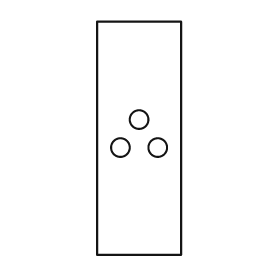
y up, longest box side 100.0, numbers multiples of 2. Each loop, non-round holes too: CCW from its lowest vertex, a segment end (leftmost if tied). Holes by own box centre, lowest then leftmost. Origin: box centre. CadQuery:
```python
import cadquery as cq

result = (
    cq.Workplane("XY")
    .moveTo(-18.0, -50.0)
    .lineTo(18.0, -50.0)
    .lineTo(18.0, 50.0)
    .lineTo(-18.0, 50.0)
    .close()
    .moveTo(-8.0, -4.0)
    .circle(4.0)
    .moveTo(8.0, -4.0)
    .circle(4.0)
    .moveTo(0.0, 8.0)
    .circle(4.0)
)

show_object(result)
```